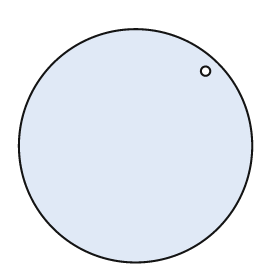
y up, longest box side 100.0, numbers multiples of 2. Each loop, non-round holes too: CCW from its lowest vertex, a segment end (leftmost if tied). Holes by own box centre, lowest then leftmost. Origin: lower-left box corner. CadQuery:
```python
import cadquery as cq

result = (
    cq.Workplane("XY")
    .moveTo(50.0, 50.0)
    .circle(50.0)
    .moveTo(80.0, 82.0)
    .circle(2.0)
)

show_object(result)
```